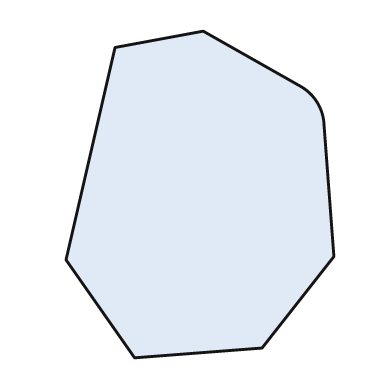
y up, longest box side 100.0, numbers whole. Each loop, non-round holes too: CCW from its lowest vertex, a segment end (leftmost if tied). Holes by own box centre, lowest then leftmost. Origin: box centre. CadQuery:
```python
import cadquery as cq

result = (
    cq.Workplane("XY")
    .moveTo(-20.0, -50.0)
    .lineTo(19.0, -47.0)
    .lineTo(41.0, -19.0)
    .lineTo(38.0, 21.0)
    .threePointArc((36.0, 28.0), (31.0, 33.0))
    .lineTo(1.0, 50.0)
    .lineTo(-26.0, 45.0)
    .lineTo(-41.0, -20.0)
    .close()
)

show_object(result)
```